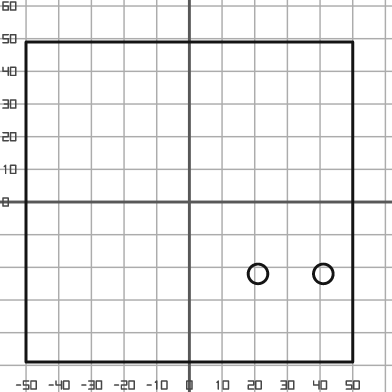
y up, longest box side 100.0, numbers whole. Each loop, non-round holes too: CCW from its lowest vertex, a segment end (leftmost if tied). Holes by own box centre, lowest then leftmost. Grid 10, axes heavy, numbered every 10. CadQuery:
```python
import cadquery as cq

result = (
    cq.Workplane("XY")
    .moveTo(-50.0, -49.0)
    .lineTo(50.0, -49.0)
    .lineTo(50.0, 49.0)
    .lineTo(-50.0, 49.0)
    .close()
    .moveTo(21.0, -22.0)
    .circle(3.0)
    .moveTo(41.0, -22.0)
    .circle(3.0)
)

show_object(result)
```